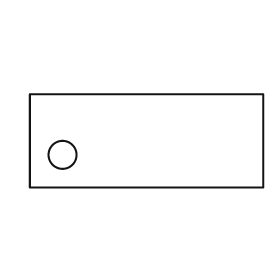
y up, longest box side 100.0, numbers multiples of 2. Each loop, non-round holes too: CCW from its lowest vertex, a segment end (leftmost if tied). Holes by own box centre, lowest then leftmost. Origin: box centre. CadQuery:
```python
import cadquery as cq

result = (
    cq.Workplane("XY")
    .moveTo(-50.0, -20.0)
    .lineTo(50.0, -20.0)
    .lineTo(50.0, 20.0)
    .lineTo(-50.0, 20.0)
    .close()
    .moveTo(-36.0, -6.0)
    .circle(6.0)
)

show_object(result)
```